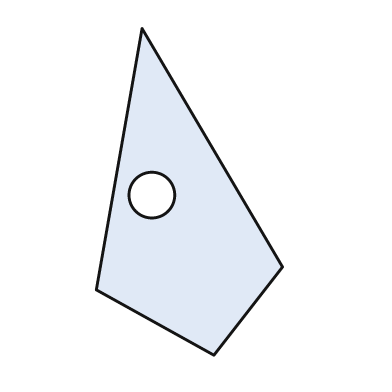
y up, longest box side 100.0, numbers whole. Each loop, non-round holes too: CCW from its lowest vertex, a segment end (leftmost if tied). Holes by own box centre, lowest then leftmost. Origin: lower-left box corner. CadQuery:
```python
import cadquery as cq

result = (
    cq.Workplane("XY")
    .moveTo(36.0, 0.0)
    .lineTo(57.0, 27.0)
    .lineTo(14.0, 100.0)
    .lineTo(0.0, 20.0)
    .close()
    .moveTo(17.0, 49.0)
    .circle(7.0)
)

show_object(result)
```